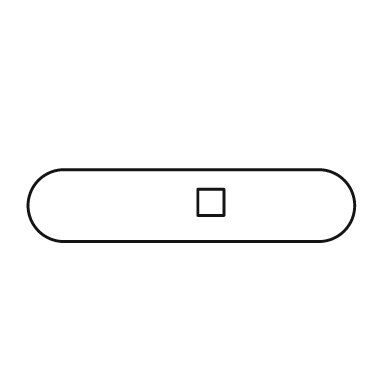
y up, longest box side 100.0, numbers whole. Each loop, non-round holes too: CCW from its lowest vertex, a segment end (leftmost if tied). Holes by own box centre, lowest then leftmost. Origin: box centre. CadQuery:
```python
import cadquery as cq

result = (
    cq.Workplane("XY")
    .moveTo(-39.0, -11.0)
    .lineTo(39.0, -11.0)
    .threePointArc((50.0, 0.0), (39.0, 11.0))
    .lineTo(-39.0, 11.0)
    .threePointArc((-50.0, 0.0), (-39.0, -11.0))
    .close()
    .moveTo(2.0, -3.0)
    .lineTo(10.0, -3.0)
    .lineTo(10.0, 5.0)
    .lineTo(2.0, 5.0)
    .close()
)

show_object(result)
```